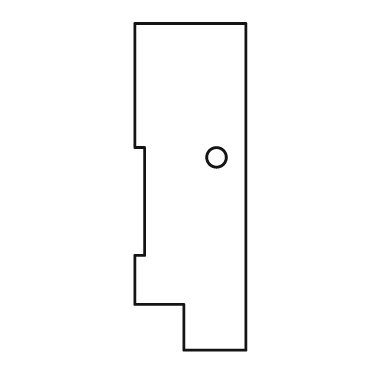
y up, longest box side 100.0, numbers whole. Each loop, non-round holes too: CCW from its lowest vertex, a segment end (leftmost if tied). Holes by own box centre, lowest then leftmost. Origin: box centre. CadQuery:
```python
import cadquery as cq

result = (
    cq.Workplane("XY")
    .moveTo(-2.0, -50.0)
    .lineTo(17.0, -50.0)
    .lineTo(17.0, 50.0)
    .lineTo(-17.0, 50.0)
    .lineTo(-17.0, 12.0)
    .lineTo(-14.0, 12.0)
    .lineTo(-14.0, -21.0)
    .lineTo(-17.0, -21.0)
    .lineTo(-17.0, -36.0)
    .lineTo(-2.0, -36.0)
    .close()
    .moveTo(8.0, 9.0)
    .circle(3.0)
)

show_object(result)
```